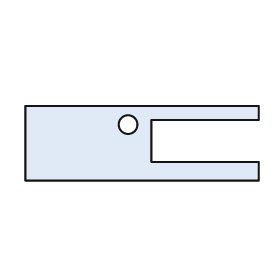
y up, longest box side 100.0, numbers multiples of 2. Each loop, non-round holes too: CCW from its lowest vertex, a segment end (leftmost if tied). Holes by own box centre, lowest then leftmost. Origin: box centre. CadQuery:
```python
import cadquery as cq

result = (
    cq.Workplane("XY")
    .moveTo(-50.0, -16.0)
    .lineTo(50.0, -16.0)
    .lineTo(50.0, -8.0)
    .lineTo(4.0, -8.0)
    .lineTo(4.0, 10.0)
    .lineTo(50.0, 10.0)
    .lineTo(50.0, 16.0)
    .lineTo(-50.0, 16.0)
    .close()
    .moveTo(-6.0, 8.0)
    .circle(4.0)
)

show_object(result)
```